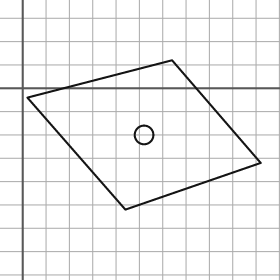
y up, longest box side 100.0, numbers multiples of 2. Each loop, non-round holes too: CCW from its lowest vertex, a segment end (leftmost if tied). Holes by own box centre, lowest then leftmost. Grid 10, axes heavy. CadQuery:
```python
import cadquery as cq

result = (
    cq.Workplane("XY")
    .moveTo(44.0, -52.0)
    .lineTo(102.0, -32.0)
    .lineTo(64.0, 12.0)
    .lineTo(2.0, -4.0)
    .close()
    .moveTo(52.0, -20.0)
    .circle(4.0)
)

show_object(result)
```